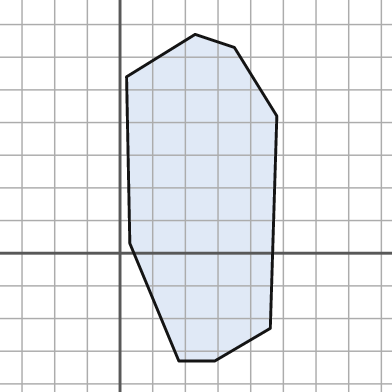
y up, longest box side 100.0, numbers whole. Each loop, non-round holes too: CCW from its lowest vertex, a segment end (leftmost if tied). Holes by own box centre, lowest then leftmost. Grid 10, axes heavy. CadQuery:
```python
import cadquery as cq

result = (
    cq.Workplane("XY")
    .moveTo(18.0, -33.0)
    .lineTo(29.0, -33.0)
    .lineTo(46.0, -23.0)
    .lineTo(48.0, 42.0)
    .lineTo(35.0, 63.0)
    .lineTo(23.0, 67.0)
    .lineTo(2.0, 54.0)
    .lineTo(3.0, 3.0)
    .close()
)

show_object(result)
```